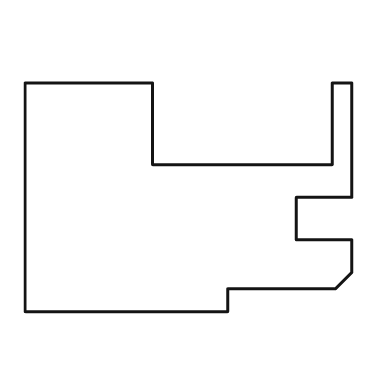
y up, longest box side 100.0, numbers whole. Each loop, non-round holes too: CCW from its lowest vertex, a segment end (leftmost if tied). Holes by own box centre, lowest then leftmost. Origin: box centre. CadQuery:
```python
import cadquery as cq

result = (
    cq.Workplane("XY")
    .moveTo(-50.0, -35.0)
    .lineTo(12.0, -35.0)
    .lineTo(12.0, -28.0)
    .lineTo(45.0, -28.0)
    .lineTo(50.0, -23.0)
    .lineTo(50.0, -13.0)
    .lineTo(33.0, -13.0)
    .lineTo(33.0, 0.0)
    .lineTo(50.0, 0.0)
    .lineTo(50.0, 35.0)
    .lineTo(44.0, 35.0)
    .lineTo(44.0, 10.0)
    .lineTo(-11.0, 10.0)
    .lineTo(-11.0, 35.0)
    .lineTo(-50.0, 35.0)
    .close()
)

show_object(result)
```